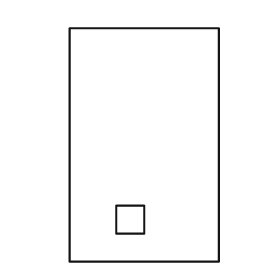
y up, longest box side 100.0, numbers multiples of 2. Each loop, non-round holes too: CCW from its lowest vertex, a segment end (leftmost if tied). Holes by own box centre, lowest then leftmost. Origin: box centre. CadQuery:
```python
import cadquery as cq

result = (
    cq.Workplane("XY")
    .moveTo(-32.0, -50.0)
    .lineTo(32.0, -50.0)
    .lineTo(32.0, 50.0)
    .lineTo(-32.0, 50.0)
    .close()
    .moveTo(-12.0, -38.0)
    .lineTo(0.0, -38.0)
    .lineTo(0.0, -26.0)
    .lineTo(-12.0, -26.0)
    .close()
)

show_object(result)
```